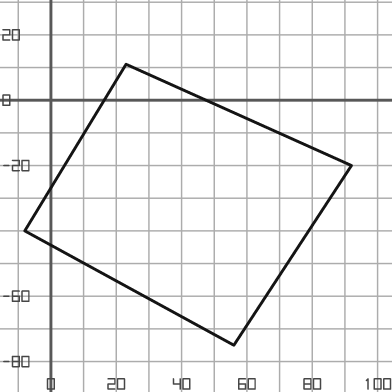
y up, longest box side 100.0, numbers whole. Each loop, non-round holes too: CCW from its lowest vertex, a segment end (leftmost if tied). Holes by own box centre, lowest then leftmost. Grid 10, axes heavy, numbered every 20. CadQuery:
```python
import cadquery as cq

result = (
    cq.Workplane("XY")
    .moveTo(56.0, -75.0)
    .lineTo(92.0, -20.0)
    .lineTo(23.0, 11.0)
    .lineTo(-8.0, -40.0)
    .close()
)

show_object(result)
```